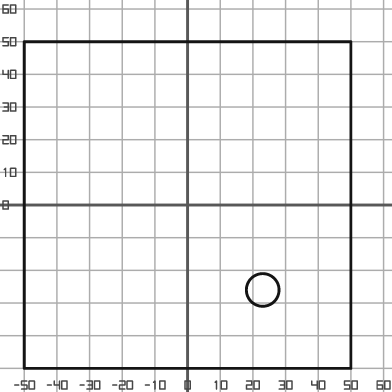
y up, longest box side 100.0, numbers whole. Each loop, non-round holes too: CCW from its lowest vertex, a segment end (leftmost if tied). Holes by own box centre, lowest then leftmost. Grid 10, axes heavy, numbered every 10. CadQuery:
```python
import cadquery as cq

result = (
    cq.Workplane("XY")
    .moveTo(-50.0, -50.0)
    .lineTo(50.0, -50.0)
    .lineTo(50.0, 50.0)
    .lineTo(-50.0, 50.0)
    .close()
    .moveTo(23.0, -26.0)
    .circle(5.0)
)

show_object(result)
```